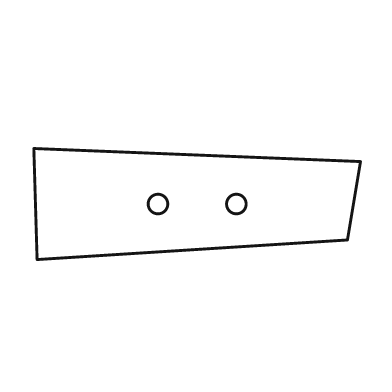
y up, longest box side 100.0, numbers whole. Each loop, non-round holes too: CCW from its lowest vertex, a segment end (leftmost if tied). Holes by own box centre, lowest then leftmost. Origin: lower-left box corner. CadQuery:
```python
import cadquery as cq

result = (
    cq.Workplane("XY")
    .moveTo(1.0, 0.0)
    .lineTo(96.0, 6.0)
    .lineTo(100.0, 30.0)
    .lineTo(0.0, 34.0)
    .close()
    .moveTo(38.0, 17.0)
    .circle(3.0)
    .moveTo(62.0, 17.0)
    .circle(3.0)
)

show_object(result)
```